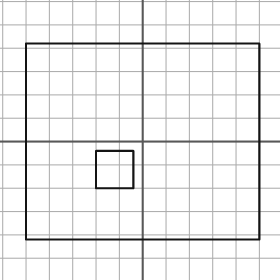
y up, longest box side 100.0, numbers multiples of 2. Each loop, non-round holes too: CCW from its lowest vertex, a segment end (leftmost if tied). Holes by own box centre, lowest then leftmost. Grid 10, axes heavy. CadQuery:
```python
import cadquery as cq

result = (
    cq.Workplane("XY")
    .moveTo(-50.0, -42.0)
    .lineTo(50.0, -42.0)
    .lineTo(50.0, 42.0)
    .lineTo(-50.0, 42.0)
    .close()
    .moveTo(-20.0, -20.0)
    .lineTo(-4.0, -20.0)
    .lineTo(-4.0, -4.0)
    .lineTo(-20.0, -4.0)
    .close()
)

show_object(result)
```